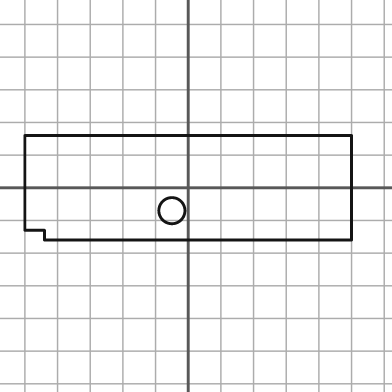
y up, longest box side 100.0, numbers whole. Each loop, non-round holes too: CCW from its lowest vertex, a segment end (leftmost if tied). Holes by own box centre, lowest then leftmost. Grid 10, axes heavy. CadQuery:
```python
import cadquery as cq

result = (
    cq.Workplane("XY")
    .moveTo(-44.0, -16.0)
    .lineTo(50.0, -16.0)
    .lineTo(50.0, 16.0)
    .lineTo(-50.0, 16.0)
    .lineTo(-50.0, -13.0)
    .lineTo(-44.0, -13.0)
    .close()
    .moveTo(-5.0, -7.0)
    .circle(4.0)
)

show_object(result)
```